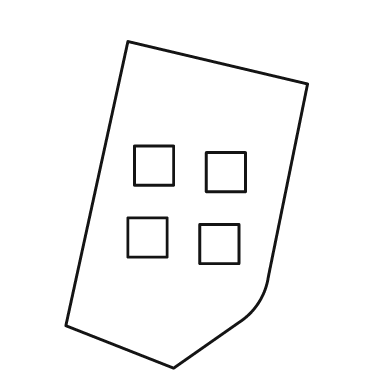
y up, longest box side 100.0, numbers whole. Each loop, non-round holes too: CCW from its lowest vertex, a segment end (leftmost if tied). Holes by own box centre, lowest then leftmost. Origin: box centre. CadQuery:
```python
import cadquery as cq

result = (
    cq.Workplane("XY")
    .moveTo(-4.0, -50.0)
    .lineTo(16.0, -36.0)
    .threePointArc((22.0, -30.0), (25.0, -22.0))
    .lineTo(37.0, 37.0)
    .lineTo(-18.0, 50.0)
    .lineTo(-37.0, -37.0)
    .close()
    .moveTo(4.0, -18.0)
    .lineTo(16.0, -18.0)
    .lineTo(16.0, -6.0)
    .lineTo(4.0, -6.0)
    .close()
    .moveTo(-18.0, -16.0)
    .lineTo(-6.0, -16.0)
    .lineTo(-6.0, -4.0)
    .lineTo(-18.0, -4.0)
    .close()
    .moveTo(6.0, 4.0)
    .lineTo(18.0, 4.0)
    .lineTo(18.0, 16.0)
    .lineTo(6.0, 16.0)
    .close()
    .moveTo(-16.0, 6.0)
    .lineTo(-4.0, 6.0)
    .lineTo(-4.0, 18.0)
    .lineTo(-16.0, 18.0)
    .close()
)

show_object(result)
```